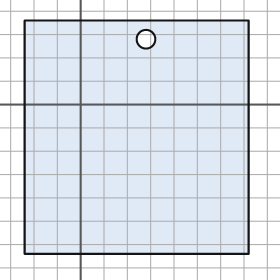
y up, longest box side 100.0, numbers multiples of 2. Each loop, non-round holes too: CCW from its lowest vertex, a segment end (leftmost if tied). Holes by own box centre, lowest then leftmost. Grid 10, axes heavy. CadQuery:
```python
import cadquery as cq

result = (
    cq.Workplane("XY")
    .moveTo(-24.0, -64.0)
    .lineTo(72.0, -64.0)
    .lineTo(72.0, 36.0)
    .lineTo(-24.0, 36.0)
    .close()
    .moveTo(28.0, 28.0)
    .circle(4.0)
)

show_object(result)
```